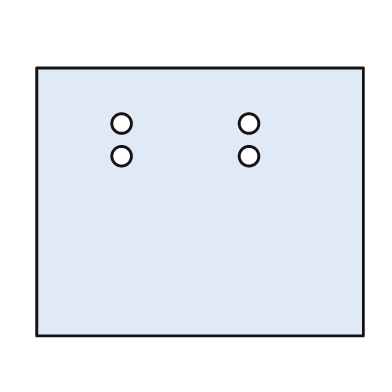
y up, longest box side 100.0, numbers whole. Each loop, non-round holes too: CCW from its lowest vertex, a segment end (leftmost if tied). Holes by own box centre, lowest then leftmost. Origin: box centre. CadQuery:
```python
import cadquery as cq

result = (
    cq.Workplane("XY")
    .moveTo(-50.0, -41.0)
    .lineTo(50.0, -41.0)
    .lineTo(50.0, 41.0)
    .lineTo(-50.0, 41.0)
    .close()
    .moveTo(-24.0, 14.0)
    .circle(3.0)
    .moveTo(15.0, 14.0)
    .circle(3.0)
    .moveTo(-24.0, 24.0)
    .circle(3.0)
    .moveTo(15.0, 24.0)
    .circle(3.0)
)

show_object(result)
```